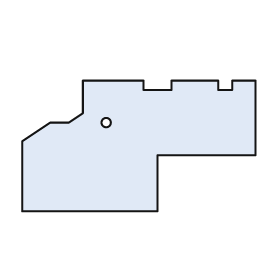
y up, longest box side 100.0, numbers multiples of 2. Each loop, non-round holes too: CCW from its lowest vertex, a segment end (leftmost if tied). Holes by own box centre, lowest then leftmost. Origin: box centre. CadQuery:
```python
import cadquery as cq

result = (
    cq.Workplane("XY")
    .moveTo(-50.0, -28.0)
    .lineTo(8.0, -28.0)
    .lineTo(8.0, -4.0)
    .lineTo(50.0, -4.0)
    .lineTo(50.0, 28.0)
    .lineTo(40.0, 28.0)
    .lineTo(40.0, 24.0)
    .lineTo(34.0, 24.0)
    .lineTo(34.0, 28.0)
    .lineTo(14.0, 28.0)
    .lineTo(14.0, 24.0)
    .lineTo(2.0, 24.0)
    .lineTo(2.0, 28.0)
    .lineTo(-24.0, 28.0)
    .lineTo(-24.0, 14.0)
    .lineTo(-30.0, 10.0)
    .lineTo(-38.0, 10.0)
    .lineTo(-50.0, 2.0)
    .close()
    .moveTo(-14.0, 10.0)
    .circle(2.0)
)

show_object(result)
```